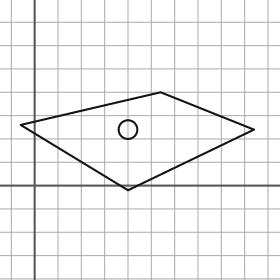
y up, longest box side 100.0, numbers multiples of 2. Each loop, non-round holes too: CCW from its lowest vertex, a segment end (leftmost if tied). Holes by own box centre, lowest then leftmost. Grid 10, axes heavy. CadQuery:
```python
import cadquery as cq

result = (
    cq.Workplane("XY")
    .moveTo(40.0, -2.0)
    .lineTo(94.0, 24.0)
    .lineTo(54.0, 40.0)
    .lineTo(-6.0, 26.0)
    .close()
    .moveTo(40.0, 24.0)
    .circle(4.0)
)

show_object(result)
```